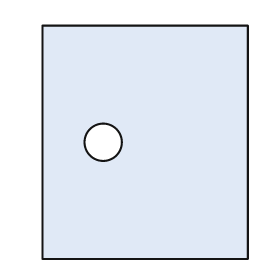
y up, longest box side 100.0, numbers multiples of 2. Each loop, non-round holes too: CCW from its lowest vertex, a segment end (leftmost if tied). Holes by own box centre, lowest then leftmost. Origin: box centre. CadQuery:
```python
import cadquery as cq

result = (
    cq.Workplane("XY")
    .moveTo(-44.0, -50.0)
    .lineTo(44.0, -50.0)
    .lineTo(44.0, 50.0)
    .lineTo(-44.0, 50.0)
    .close()
    .moveTo(-18.0, 0.0)
    .circle(8.0)
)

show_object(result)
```